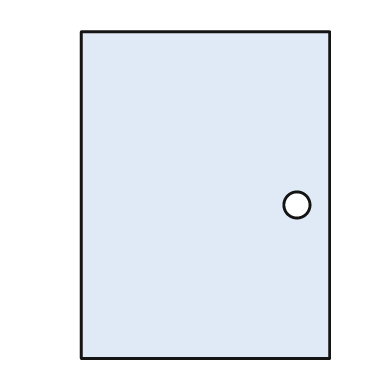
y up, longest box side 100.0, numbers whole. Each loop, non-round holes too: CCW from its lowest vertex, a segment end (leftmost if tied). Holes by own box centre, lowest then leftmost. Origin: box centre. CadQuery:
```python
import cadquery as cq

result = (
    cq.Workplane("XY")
    .moveTo(-38.0, -50.0)
    .lineTo(38.0, -50.0)
    .lineTo(38.0, 50.0)
    .lineTo(-38.0, 50.0)
    .close()
    .moveTo(28.0, -3.0)
    .circle(4.0)
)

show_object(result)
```